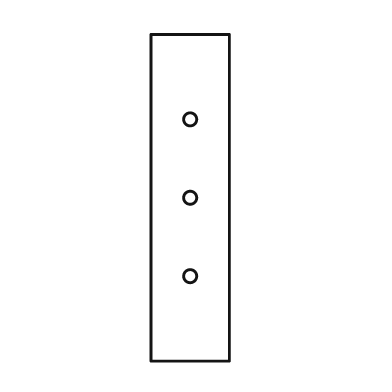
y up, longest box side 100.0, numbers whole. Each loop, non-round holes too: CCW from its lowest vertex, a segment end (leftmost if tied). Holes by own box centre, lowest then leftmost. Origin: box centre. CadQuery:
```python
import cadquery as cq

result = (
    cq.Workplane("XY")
    .moveTo(-12.0, -50.0)
    .lineTo(12.0, -50.0)
    .lineTo(12.0, 50.0)
    .lineTo(-12.0, 50.0)
    .close()
    .moveTo(0.0, -24.0)
    .circle(2.0)
    .moveTo(0.0, 0.0)
    .circle(2.0)
    .moveTo(0.0, 24.0)
    .circle(2.0)
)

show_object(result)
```